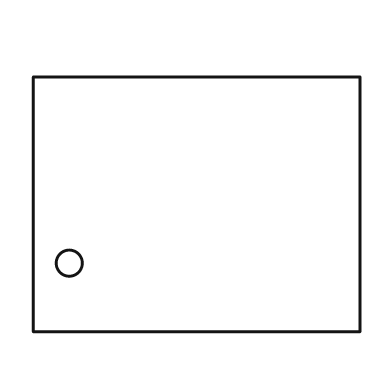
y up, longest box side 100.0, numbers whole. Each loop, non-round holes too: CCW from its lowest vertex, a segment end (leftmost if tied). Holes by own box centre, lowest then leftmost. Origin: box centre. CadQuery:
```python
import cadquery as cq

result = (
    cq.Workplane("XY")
    .moveTo(-50.0, -39.0)
    .lineTo(50.0, -39.0)
    .lineTo(50.0, 39.0)
    .lineTo(-50.0, 39.0)
    .close()
    .moveTo(-39.0, -18.0)
    .circle(4.0)
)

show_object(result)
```